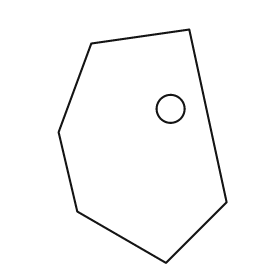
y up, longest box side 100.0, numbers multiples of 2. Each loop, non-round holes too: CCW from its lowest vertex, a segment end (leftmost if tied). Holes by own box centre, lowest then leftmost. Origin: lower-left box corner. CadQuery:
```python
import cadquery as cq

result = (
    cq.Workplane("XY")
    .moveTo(46.0, 0.0)
    .lineTo(72.0, 26.0)
    .lineTo(56.0, 100.0)
    .lineTo(14.0, 94.0)
    .lineTo(0.0, 56.0)
    .lineTo(8.0, 22.0)
    .close()
    .moveTo(48.0, 66.0)
    .circle(6.0)
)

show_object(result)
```